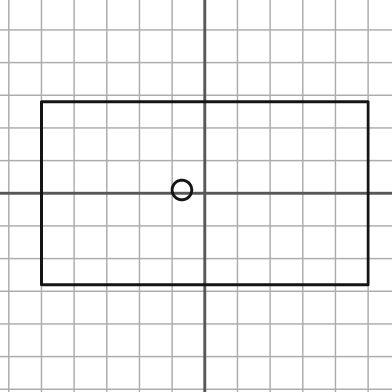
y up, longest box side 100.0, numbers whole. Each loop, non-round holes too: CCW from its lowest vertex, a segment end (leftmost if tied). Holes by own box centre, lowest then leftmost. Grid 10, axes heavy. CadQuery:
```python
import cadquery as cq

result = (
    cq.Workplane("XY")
    .moveTo(-50.0, -28.0)
    .lineTo(50.0, -28.0)
    .lineTo(50.0, 28.0)
    .lineTo(-50.0, 28.0)
    .close()
    .moveTo(-7.0, 1.0)
    .circle(3.0)
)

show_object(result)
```